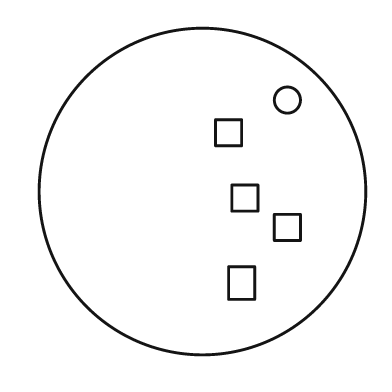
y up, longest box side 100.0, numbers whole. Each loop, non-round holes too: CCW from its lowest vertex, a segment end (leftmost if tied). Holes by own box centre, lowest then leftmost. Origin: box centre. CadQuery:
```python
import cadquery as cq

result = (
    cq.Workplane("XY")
    .moveTo(0.0, 0.0)
    .circle(50.0)
    .moveTo(8.0, -33.0)
    .lineTo(16.0, -33.0)
    .lineTo(16.0, -23.0)
    .lineTo(8.0, -23.0)
    .close()
    .moveTo(22.0, -15.0)
    .lineTo(30.0, -15.0)
    .lineTo(30.0, -7.0)
    .lineTo(22.0, -7.0)
    .close()
    .moveTo(9.0, -6.0)
    .lineTo(17.0, -6.0)
    .lineTo(17.0, 2.0)
    .lineTo(9.0, 2.0)
    .close()
    .moveTo(4.0, 14.0)
    .lineTo(12.0, 14.0)
    .lineTo(12.0, 22.0)
    .lineTo(4.0, 22.0)
    .close()
    .moveTo(26.0, 28.0)
    .circle(4.0)
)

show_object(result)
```